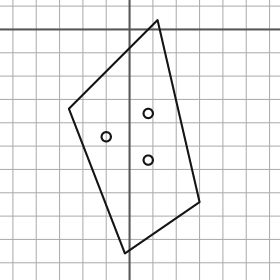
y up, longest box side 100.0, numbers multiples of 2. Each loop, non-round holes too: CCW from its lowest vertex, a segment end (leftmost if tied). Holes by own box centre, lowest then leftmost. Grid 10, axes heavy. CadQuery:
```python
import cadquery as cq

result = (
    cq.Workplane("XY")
    .moveTo(-2.0, -96.0)
    .lineTo(30.0, -74.0)
    .lineTo(12.0, 4.0)
    .lineTo(-26.0, -34.0)
    .close()
    .moveTo(8.0, -56.0)
    .circle(2.0)
    .moveTo(-10.0, -46.0)
    .circle(2.0)
    .moveTo(8.0, -36.0)
    .circle(2.0)
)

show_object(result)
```